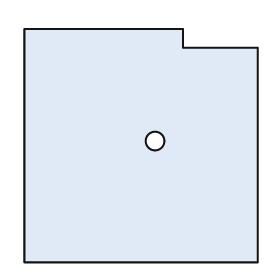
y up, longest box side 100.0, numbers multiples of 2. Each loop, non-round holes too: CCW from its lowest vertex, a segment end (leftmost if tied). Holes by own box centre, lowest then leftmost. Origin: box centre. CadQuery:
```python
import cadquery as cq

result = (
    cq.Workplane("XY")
    .moveTo(-50.0, -50.0)
    .lineTo(50.0, -50.0)
    .lineTo(50.0, 42.0)
    .lineTo(18.0, 42.0)
    .lineTo(18.0, 50.0)
    .lineTo(-50.0, 50.0)
    .close()
    .moveTo(6.0, 2.0)
    .circle(4.0)
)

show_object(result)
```